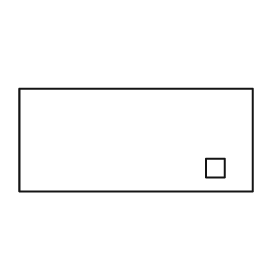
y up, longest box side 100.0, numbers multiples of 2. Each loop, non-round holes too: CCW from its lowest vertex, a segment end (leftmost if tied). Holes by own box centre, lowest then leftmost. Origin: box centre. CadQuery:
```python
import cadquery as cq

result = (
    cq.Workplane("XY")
    .moveTo(-50.0, -22.0)
    .lineTo(50.0, -22.0)
    .lineTo(50.0, 22.0)
    .lineTo(-50.0, 22.0)
    .close()
    .moveTo(30.0, -16.0)
    .lineTo(38.0, -16.0)
    .lineTo(38.0, -8.0)
    .lineTo(30.0, -8.0)
    .close()
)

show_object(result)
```